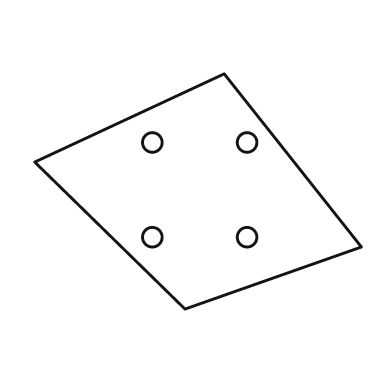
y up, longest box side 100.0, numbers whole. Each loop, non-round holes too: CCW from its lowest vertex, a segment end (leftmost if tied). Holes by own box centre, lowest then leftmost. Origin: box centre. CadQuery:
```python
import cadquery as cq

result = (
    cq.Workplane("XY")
    .moveTo(-4.0, -36.0)
    .lineTo(50.0, -17.0)
    .lineTo(8.0, 36.0)
    .lineTo(-50.0, 9.0)
    .close()
    .moveTo(-14.0, -14.0)
    .circle(3.0)
    .moveTo(15.0, -14.0)
    .circle(3.0)
    .moveTo(-14.0, 15.0)
    .circle(3.0)
    .moveTo(15.0, 15.0)
    .circle(3.0)
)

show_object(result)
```